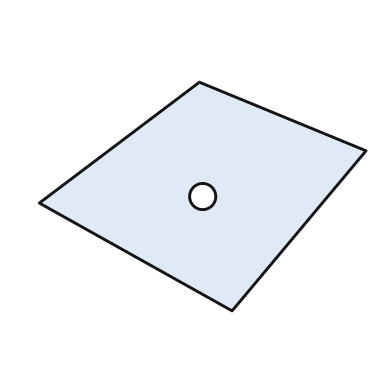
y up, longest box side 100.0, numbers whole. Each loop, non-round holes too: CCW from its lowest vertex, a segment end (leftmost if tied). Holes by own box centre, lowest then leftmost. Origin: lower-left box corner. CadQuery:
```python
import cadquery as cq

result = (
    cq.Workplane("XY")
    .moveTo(59.0, 0.0)
    .lineTo(100.0, 49.0)
    .lineTo(49.0, 70.0)
    .lineTo(0.0, 33.0)
    .close()
    .moveTo(50.0, 35.0)
    .circle(4.0)
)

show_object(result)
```